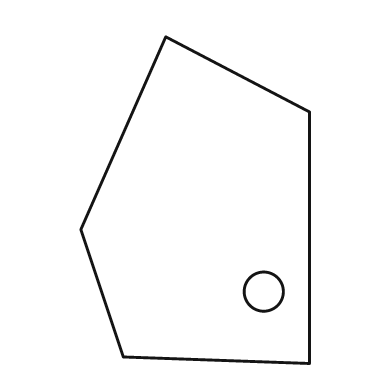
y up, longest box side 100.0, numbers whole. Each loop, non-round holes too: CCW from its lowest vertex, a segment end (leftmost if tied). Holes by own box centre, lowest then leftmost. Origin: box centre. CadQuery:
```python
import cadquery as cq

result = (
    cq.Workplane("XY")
    .moveTo(35.0, -50.0)
    .lineTo(35.0, 27.0)
    .lineTo(-9.0, 50.0)
    .lineTo(-35.0, -9.0)
    .lineTo(-22.0, -48.0)
    .close()
    .moveTo(21.0, -28.0)
    .circle(6.0)
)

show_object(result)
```